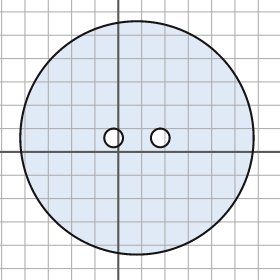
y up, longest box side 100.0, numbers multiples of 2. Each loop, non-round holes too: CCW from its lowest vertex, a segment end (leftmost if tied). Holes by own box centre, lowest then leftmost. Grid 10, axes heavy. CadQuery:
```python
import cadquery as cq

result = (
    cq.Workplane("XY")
    .moveTo(8.0, 6.0)
    .circle(50.0)
    .moveTo(-2.0, 6.0)
    .circle(4.0)
    .moveTo(18.0, 6.0)
    .circle(4.0)
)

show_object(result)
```